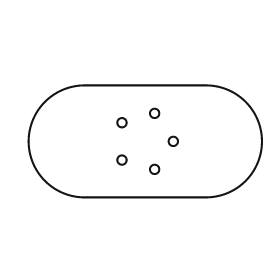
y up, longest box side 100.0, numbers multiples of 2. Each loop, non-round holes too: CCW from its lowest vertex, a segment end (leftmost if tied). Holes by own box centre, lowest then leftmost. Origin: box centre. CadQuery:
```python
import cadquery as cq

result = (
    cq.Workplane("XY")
    .moveTo(-26.0, -24.0)
    .lineTo(26.0, -24.0)
    .threePointArc((50.0, 0.0), (26.0, 24.0))
    .lineTo(-26.0, 24.0)
    .threePointArc((-50.0, 0.0), (-26.0, -24.0))
    .close()
    .moveTo(4.0, -12.0)
    .circle(2.0)
    .moveTo(-10.0, -8.0)
    .circle(2.0)
    .moveTo(12.0, 0.0)
    .circle(2.0)
    .moveTo(-10.0, 8.0)
    .circle(2.0)
    .moveTo(4.0, 12.0)
    .circle(2.0)
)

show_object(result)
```